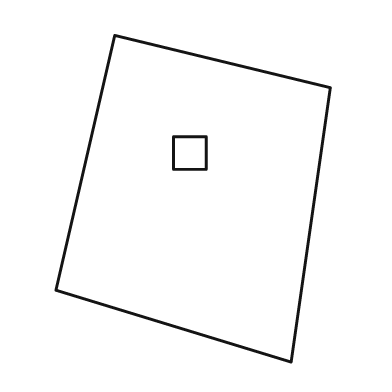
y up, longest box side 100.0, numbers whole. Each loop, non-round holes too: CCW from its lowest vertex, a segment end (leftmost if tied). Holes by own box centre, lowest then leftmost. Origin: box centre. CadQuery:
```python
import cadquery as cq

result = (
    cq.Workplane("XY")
    .moveTo(30.0, -50.0)
    .lineTo(42.0, 34.0)
    .lineTo(-24.0, 50.0)
    .lineTo(-42.0, -28.0)
    .close()
    .moveTo(-6.0, 9.0)
    .lineTo(4.0, 9.0)
    .lineTo(4.0, 19.0)
    .lineTo(-6.0, 19.0)
    .close()
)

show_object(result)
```